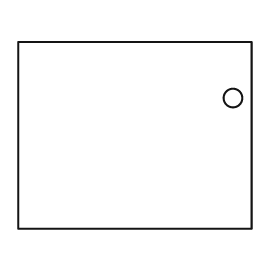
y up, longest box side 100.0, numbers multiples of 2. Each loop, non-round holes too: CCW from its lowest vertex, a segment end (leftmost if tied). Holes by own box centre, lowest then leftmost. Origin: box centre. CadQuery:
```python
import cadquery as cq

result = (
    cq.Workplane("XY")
    .moveTo(-50.0, -40.0)
    .lineTo(50.0, -40.0)
    .lineTo(50.0, 40.0)
    .lineTo(-50.0, 40.0)
    .close()
    .moveTo(42.0, 16.0)
    .circle(4.0)
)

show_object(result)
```